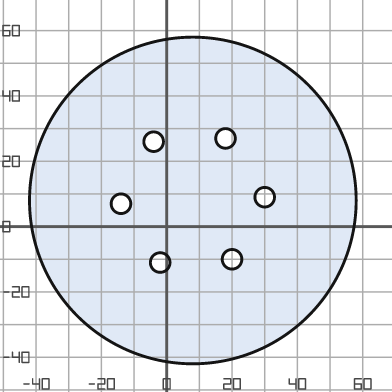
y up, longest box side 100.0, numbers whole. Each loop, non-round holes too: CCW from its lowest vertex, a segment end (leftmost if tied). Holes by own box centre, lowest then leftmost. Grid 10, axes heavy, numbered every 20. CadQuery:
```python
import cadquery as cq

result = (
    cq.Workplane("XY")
    .moveTo(8.0, 8.0)
    .circle(50.0)
    .moveTo(-2.0, -11.0)
    .circle(3.0)
    .moveTo(20.0, -10.0)
    .circle(3.0)
    .moveTo(-14.0, 7.0)
    .circle(3.0)
    .moveTo(30.0, 9.0)
    .circle(3.0)
    .moveTo(-4.0, 26.0)
    .circle(3.0)
    .moveTo(18.0, 27.0)
    .circle(3.0)
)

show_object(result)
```